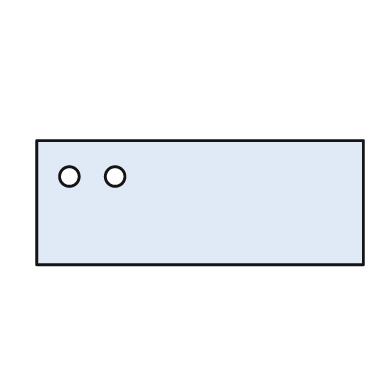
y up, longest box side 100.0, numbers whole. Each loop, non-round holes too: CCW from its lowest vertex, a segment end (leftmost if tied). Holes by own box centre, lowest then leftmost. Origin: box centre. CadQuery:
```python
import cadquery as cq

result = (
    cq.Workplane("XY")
    .moveTo(-50.0, -19.0)
    .lineTo(50.0, -19.0)
    .lineTo(50.0, 19.0)
    .lineTo(-50.0, 19.0)
    .close()
    .moveTo(-40.0, 8.0)
    .circle(3.0)
    .moveTo(-26.0, 8.0)
    .circle(3.0)
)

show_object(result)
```